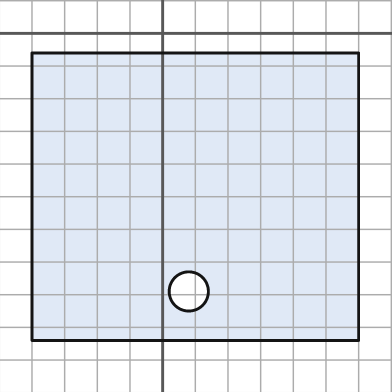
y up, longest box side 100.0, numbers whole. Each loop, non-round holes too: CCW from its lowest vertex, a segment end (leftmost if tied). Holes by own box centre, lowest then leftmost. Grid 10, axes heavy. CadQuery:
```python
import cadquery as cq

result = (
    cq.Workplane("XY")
    .moveTo(-40.0, -94.0)
    .lineTo(60.0, -94.0)
    .lineTo(60.0, -6.0)
    .lineTo(-40.0, -6.0)
    .close()
    .moveTo(8.0, -79.0)
    .circle(6.0)
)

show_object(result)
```